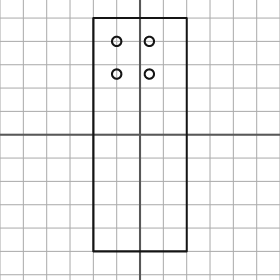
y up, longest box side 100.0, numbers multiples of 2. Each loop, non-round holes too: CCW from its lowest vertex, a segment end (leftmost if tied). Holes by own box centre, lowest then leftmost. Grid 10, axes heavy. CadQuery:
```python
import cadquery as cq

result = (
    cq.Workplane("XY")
    .moveTo(-20.0, -50.0)
    .lineTo(20.0, -50.0)
    .lineTo(20.0, 50.0)
    .lineTo(-20.0, 50.0)
    .close()
    .moveTo(-10.0, 26.0)
    .circle(2.0)
    .moveTo(4.0, 26.0)
    .circle(2.0)
    .moveTo(-10.0, 40.0)
    .circle(2.0)
    .moveTo(4.0, 40.0)
    .circle(2.0)
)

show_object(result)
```